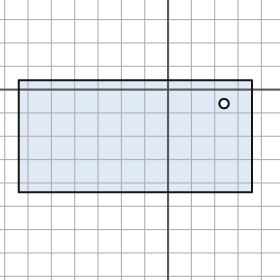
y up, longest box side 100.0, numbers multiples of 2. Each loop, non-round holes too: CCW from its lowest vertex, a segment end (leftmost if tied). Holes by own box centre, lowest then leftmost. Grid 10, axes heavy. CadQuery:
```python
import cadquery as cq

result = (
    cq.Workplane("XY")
    .moveTo(-64.0, -44.0)
    .lineTo(36.0, -44.0)
    .lineTo(36.0, 4.0)
    .lineTo(-64.0, 4.0)
    .close()
    .moveTo(24.0, -6.0)
    .circle(2.0)
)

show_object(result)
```